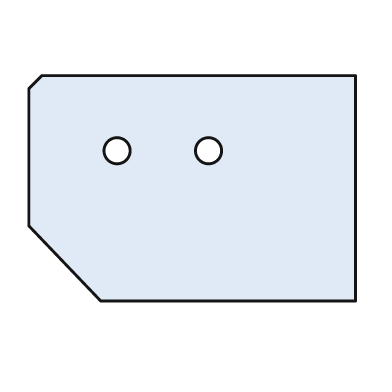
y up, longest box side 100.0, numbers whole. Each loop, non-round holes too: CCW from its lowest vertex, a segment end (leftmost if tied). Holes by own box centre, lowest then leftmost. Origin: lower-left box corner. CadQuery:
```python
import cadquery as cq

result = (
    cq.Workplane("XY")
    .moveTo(22.0, 0.0)
    .lineTo(100.0, 0.0)
    .lineTo(100.0, 69.0)
    .lineTo(4.0, 69.0)
    .lineTo(0.0, 65.0)
    .lineTo(0.0, 23.0)
    .close()
    .moveTo(27.0, 46.0)
    .circle(4.0)
    .moveTo(55.0, 46.0)
    .circle(4.0)
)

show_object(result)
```